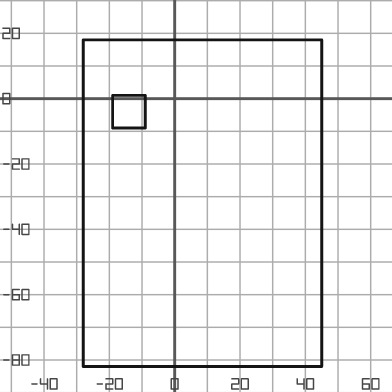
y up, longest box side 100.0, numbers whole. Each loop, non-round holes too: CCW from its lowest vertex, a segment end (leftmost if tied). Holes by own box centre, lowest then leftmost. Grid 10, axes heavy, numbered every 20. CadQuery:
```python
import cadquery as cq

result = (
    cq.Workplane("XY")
    .moveTo(-28.0, -82.0)
    .lineTo(45.0, -82.0)
    .lineTo(45.0, 18.0)
    .lineTo(-28.0, 18.0)
    .close()
    .moveTo(-19.0, -9.0)
    .lineTo(-9.0, -9.0)
    .lineTo(-9.0, 1.0)
    .lineTo(-19.0, 1.0)
    .close()
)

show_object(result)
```